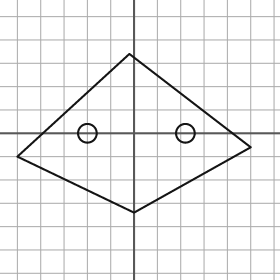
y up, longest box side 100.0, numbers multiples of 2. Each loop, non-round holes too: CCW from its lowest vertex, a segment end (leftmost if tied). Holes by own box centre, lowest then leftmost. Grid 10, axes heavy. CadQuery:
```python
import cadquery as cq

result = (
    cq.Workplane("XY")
    .moveTo(0.0, -34.0)
    .lineTo(50.0, -6.0)
    .lineTo(-2.0, 34.0)
    .lineTo(-50.0, -10.0)
    .close()
    .moveTo(-20.0, 0.0)
    .circle(4.0)
    .moveTo(22.0, 0.0)
    .circle(4.0)
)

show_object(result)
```